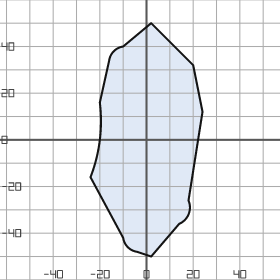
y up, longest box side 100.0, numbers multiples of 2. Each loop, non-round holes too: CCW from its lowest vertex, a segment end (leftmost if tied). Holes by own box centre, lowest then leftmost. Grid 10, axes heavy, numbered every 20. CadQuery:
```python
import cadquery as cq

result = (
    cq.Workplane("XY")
    .moveTo(2.0, -50.0)
    .lineTo(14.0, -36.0)
    .threePointArc((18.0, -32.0), (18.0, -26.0))
    .lineTo(24.0, 12.0)
    .lineTo(20.0, 32.0)
    .lineTo(2.0, 50.0)
    .lineTo(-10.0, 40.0)
    .threePointArc((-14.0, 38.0), (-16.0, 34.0))
    .lineTo(-20.0, 16.0)
    .threePointArc((-20.0, 0.0), (-24.0, -16.0))
    .lineTo(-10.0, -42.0)
    .threePointArc((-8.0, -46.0), (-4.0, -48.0))
    .close()
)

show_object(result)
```